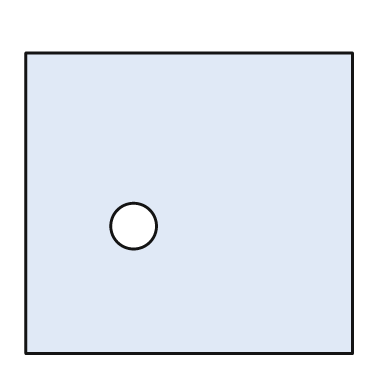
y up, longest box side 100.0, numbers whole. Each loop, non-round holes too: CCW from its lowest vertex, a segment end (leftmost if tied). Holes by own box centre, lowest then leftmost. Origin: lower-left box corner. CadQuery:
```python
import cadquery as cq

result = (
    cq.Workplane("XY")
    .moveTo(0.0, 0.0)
    .lineTo(100.0, 0.0)
    .lineTo(100.0, 92.0)
    .lineTo(0.0, 92.0)
    .close()
    .moveTo(33.0, 39.0)
    .circle(7.0)
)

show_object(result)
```